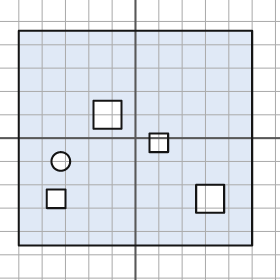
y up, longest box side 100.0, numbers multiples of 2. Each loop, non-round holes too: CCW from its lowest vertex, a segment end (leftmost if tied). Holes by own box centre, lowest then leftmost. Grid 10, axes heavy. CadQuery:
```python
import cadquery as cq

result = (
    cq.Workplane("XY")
    .moveTo(-50.0, -46.0)
    .lineTo(50.0, -46.0)
    .lineTo(50.0, 46.0)
    .lineTo(-50.0, 46.0)
    .close()
    .moveTo(-38.0, -30.0)
    .lineTo(-30.0, -30.0)
    .lineTo(-30.0, -22.0)
    .lineTo(-38.0, -22.0)
    .close()
    .moveTo(26.0, -32.0)
    .lineTo(38.0, -32.0)
    .lineTo(38.0, -20.0)
    .lineTo(26.0, -20.0)
    .close()
    .moveTo(-32.0, -10.0)
    .circle(4.0)
    .moveTo(6.0, -6.0)
    .lineTo(14.0, -6.0)
    .lineTo(14.0, 2.0)
    .lineTo(6.0, 2.0)
    .close()
    .moveTo(-18.0, 4.0)
    .lineTo(-6.0, 4.0)
    .lineTo(-6.0, 16.0)
    .lineTo(-18.0, 16.0)
    .close()
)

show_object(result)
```